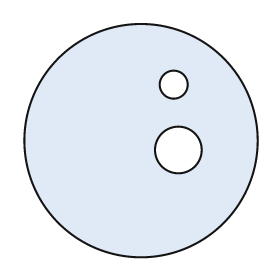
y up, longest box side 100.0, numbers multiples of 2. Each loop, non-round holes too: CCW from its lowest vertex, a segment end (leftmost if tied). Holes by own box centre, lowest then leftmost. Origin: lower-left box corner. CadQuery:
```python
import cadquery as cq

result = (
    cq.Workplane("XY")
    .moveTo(50.0, 50.0)
    .circle(50.0)
    .moveTo(66.0, 46.0)
    .circle(10.0)
    .moveTo(64.0, 74.0)
    .circle(6.0)
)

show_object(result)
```